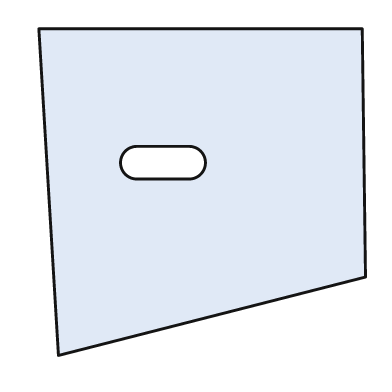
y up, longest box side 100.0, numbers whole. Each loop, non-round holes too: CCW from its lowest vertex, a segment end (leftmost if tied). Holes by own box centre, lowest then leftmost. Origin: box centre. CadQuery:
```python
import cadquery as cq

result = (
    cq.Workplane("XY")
    .moveTo(-44.0, -50.0)
    .lineTo(50.0, -26.0)
    .lineTo(49.0, 50.0)
    .lineTo(-50.0, 50.0)
    .close()
    .moveTo(-20.0, 4.0)
    .lineTo(-4.0, 4.0)
    .threePointArc((1.0, 9.0), (-4.0, 14.0))
    .lineTo(-20.0, 14.0)
    .threePointArc((-25.0, 9.0), (-20.0, 4.0))
    .close()
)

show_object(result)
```